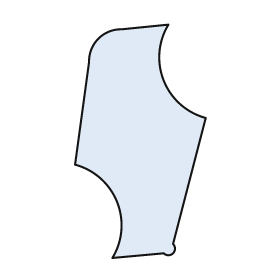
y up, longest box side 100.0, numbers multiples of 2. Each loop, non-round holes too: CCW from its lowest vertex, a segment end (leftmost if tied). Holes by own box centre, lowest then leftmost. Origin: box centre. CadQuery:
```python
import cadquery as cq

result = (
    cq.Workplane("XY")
    .moveTo(-12.0, -50.0)
    .lineTo(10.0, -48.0)
    .threePointArc((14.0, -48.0), (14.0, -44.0))
    .lineTo(28.0, 10.0)
    .threePointArc((10.0, 26.0), (12.0, 50.0))
    .lineTo(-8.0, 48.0)
    .threePointArc((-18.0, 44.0), (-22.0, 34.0))
    .lineTo(-28.0, -10.0)
    .threePointArc((-10.0, -26.0), (-12.0, -50.0))
    .close()
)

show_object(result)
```